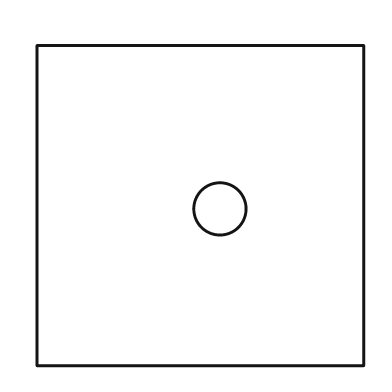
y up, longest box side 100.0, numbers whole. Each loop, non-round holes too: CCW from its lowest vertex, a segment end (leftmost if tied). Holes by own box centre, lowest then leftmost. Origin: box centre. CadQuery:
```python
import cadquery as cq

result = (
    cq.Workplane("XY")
    .moveTo(-50.0, -49.0)
    .lineTo(50.0, -49.0)
    .lineTo(50.0, 49.0)
    .lineTo(-50.0, 49.0)
    .close()
    .moveTo(6.0, -1.0)
    .circle(8.0)
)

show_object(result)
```